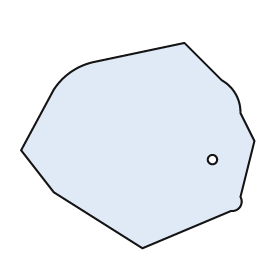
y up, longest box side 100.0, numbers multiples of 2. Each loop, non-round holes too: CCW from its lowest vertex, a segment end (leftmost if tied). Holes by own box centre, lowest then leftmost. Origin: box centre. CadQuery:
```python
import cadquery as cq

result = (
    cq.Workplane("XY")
    .moveTo(2.0, -44.0)
    .lineTo(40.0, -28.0)
    .threePointArc((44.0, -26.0), (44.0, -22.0))
    .lineTo(50.0, 2.0)
    .lineTo(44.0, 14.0)
    .threePointArc((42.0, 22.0), (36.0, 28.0))
    .lineTo(20.0, 44.0)
    .lineTo(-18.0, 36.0)
    .threePointArc((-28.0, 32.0), (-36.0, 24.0))
    .lineTo(-50.0, -2.0)
    .lineTo(-36.0, -20.0)
    .close()
    .moveTo(32.0, -6.0)
    .circle(2.0)
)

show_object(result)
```